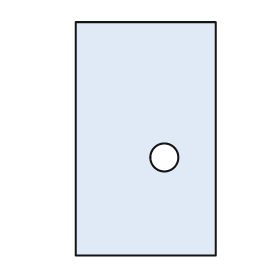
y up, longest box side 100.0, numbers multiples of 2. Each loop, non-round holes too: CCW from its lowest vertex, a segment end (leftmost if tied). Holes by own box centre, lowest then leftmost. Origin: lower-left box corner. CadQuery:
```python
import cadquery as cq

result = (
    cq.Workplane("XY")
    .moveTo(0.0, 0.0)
    .lineTo(60.0, 0.0)
    .lineTo(60.0, 100.0)
    .lineTo(0.0, 100.0)
    .close()
    .moveTo(38.0, 42.0)
    .circle(6.0)
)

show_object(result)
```